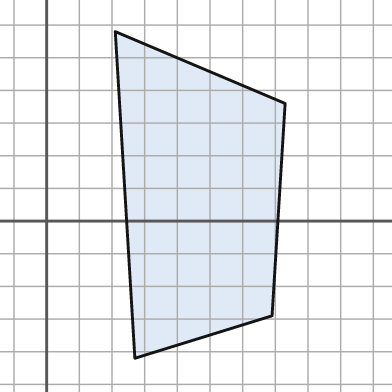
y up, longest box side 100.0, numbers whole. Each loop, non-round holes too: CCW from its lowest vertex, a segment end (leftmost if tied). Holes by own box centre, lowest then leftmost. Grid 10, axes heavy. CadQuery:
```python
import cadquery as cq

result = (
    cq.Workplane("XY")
    .moveTo(27.0, -42.0)
    .lineTo(69.0, -29.0)
    .lineTo(73.0, 36.0)
    .lineTo(21.0, 58.0)
    .close()
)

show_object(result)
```